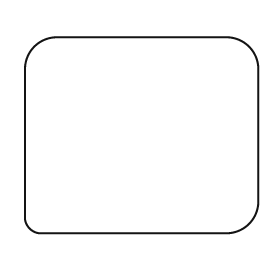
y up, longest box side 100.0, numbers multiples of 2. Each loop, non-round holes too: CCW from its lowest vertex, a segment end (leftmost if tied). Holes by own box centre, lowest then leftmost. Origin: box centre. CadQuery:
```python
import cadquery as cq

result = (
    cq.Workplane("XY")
    .moveTo(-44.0, -42.0)
    .lineTo(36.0, -42.0)
    .threePointArc((46.0, -38.0), (50.0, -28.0))
    .lineTo(50.0, 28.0)
    .threePointArc((46.0, 38.0), (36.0, 42.0))
    .lineTo(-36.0, 42.0)
    .threePointArc((-46.0, 38.0), (-50.0, 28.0))
    .lineTo(-50.0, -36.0)
    .threePointArc((-48.0, -40.0), (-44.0, -42.0))
    .close()
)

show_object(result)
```